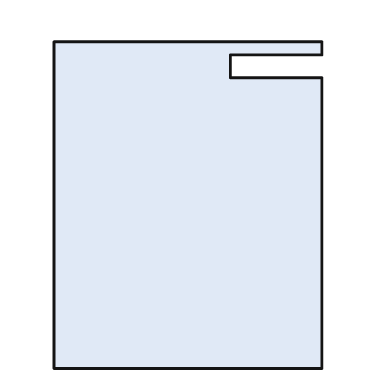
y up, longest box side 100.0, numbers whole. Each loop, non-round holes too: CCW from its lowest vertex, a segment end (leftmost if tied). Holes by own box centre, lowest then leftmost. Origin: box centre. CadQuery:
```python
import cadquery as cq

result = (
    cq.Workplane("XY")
    .moveTo(-41.0, -50.0)
    .lineTo(41.0, -50.0)
    .lineTo(41.0, 39.0)
    .lineTo(13.0, 39.0)
    .lineTo(13.0, 46.0)
    .lineTo(41.0, 46.0)
    .lineTo(41.0, 50.0)
    .lineTo(-41.0, 50.0)
    .close()
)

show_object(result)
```